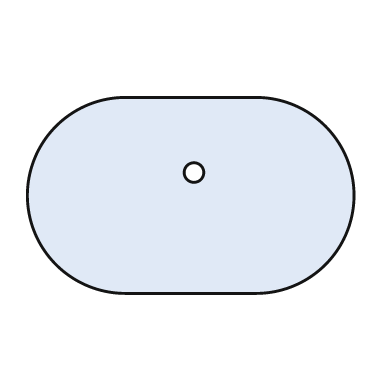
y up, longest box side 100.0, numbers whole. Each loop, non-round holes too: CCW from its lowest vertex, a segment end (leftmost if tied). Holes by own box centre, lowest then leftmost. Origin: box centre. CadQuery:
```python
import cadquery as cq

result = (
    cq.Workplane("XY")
    .moveTo(-20.0, -30.0)
    .lineTo(20.0, -30.0)
    .threePointArc((50.0, 0.0), (20.0, 30.0))
    .lineTo(-20.0, 30.0)
    .threePointArc((-50.0, 0.0), (-20.0, -30.0))
    .close()
    .moveTo(1.0, 7.0)
    .circle(3.0)
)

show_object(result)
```